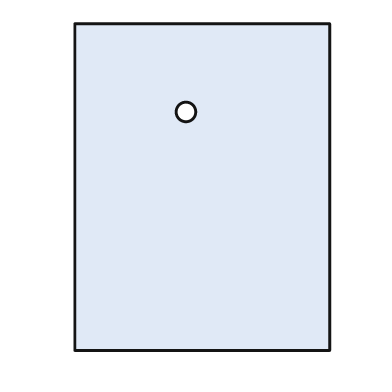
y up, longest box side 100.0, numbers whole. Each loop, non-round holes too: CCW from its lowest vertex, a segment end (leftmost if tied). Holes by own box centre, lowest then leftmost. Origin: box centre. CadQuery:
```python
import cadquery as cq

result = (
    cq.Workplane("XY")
    .moveTo(-39.0, -50.0)
    .lineTo(39.0, -50.0)
    .lineTo(39.0, 50.0)
    .lineTo(-39.0, 50.0)
    .close()
    .moveTo(-5.0, 23.0)
    .circle(3.0)
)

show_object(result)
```